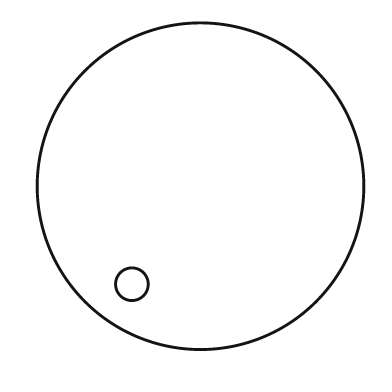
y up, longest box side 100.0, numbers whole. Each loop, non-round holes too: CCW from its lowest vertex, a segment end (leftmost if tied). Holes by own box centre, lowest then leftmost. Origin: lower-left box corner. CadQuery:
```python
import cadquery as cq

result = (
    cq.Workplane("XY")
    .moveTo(50.0, 50.0)
    .circle(50.0)
    .moveTo(29.0, 20.0)
    .circle(5.0)
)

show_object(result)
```